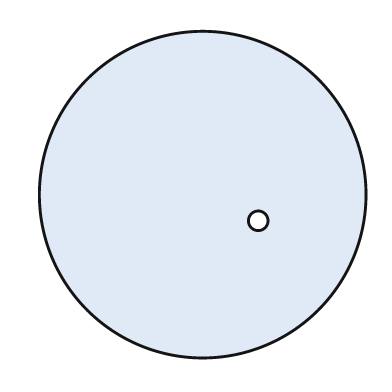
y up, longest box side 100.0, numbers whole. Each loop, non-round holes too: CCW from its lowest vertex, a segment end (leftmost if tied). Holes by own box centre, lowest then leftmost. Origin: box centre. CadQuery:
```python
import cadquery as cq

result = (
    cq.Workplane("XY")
    .moveTo(0.0, 0.0)
    .circle(50.0)
    .moveTo(17.0, -8.0)
    .circle(3.0)
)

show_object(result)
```